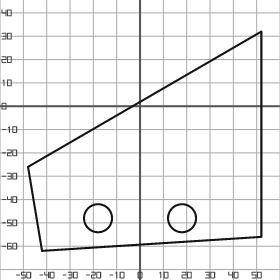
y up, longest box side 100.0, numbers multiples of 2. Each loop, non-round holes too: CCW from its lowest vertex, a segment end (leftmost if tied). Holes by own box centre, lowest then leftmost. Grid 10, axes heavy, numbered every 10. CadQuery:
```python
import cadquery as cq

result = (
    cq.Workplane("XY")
    .moveTo(-42.0, -62.0)
    .lineTo(52.0, -56.0)
    .lineTo(52.0, 32.0)
    .lineTo(-48.0, -26.0)
    .close()
    .moveTo(-18.0, -48.0)
    .circle(6.0)
    .moveTo(18.0, -48.0)
    .circle(6.0)
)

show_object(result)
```